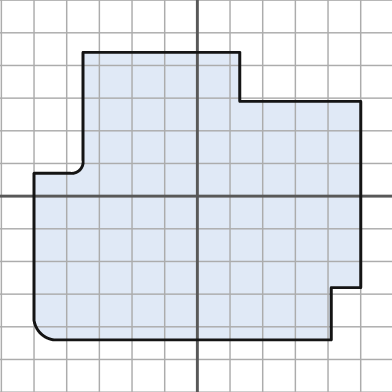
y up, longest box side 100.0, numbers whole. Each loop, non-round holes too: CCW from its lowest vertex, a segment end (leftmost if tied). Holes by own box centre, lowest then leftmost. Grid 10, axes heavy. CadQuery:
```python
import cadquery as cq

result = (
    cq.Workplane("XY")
    .moveTo(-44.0, -44.0)
    .lineTo(41.0, -44.0)
    .lineTo(41.0, -28.0)
    .lineTo(50.0, -28.0)
    .lineTo(50.0, 29.0)
    .lineTo(13.0, 29.0)
    .lineTo(13.0, 44.0)
    .lineTo(-35.0, 44.0)
    .lineTo(-35.0, 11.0)
    .threePointArc((-36.0, 8.0), (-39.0, 7.0))
    .lineTo(-50.0, 7.0)
    .lineTo(-50.0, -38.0)
    .threePointArc((-48.0, -42.0), (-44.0, -44.0))
    .close()
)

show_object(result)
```